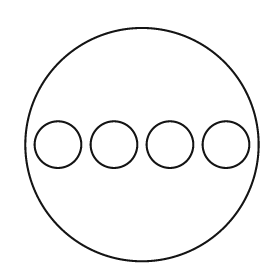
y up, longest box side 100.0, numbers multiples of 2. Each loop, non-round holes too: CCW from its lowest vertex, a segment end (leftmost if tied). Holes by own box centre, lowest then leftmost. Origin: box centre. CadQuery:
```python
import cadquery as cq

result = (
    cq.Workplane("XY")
    .moveTo(0.0, 0.0)
    .circle(50.0)
    .moveTo(-36.0, 0.0)
    .circle(10.0)
    .moveTo(-12.0, 0.0)
    .circle(10.0)
    .moveTo(12.0, 0.0)
    .circle(10.0)
    .moveTo(36.0, 0.0)
    .circle(10.0)
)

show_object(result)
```